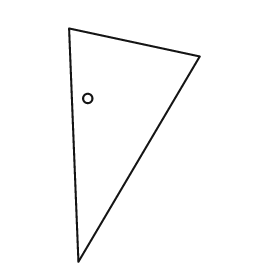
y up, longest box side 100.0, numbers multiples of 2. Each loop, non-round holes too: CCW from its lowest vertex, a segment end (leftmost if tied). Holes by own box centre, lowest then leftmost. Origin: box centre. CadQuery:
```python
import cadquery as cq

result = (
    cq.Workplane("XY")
    .moveTo(-24.0, -50.0)
    .lineTo(28.0, 38.0)
    .lineTo(-28.0, 50.0)
    .close()
    .moveTo(-20.0, 20.0)
    .circle(2.0)
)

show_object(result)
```